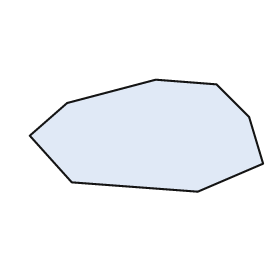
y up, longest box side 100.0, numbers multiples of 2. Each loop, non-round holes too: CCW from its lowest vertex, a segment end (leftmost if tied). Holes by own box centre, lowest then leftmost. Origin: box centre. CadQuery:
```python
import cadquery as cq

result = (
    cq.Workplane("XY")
    .moveTo(22.0, -24.0)
    .lineTo(50.0, -12.0)
    .lineTo(44.0, 8.0)
    .lineTo(30.0, 22.0)
    .lineTo(4.0, 24.0)
    .lineTo(-34.0, 14.0)
    .lineTo(-50.0, 0.0)
    .lineTo(-32.0, -20.0)
    .close()
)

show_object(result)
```